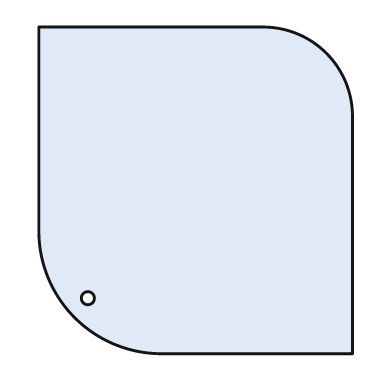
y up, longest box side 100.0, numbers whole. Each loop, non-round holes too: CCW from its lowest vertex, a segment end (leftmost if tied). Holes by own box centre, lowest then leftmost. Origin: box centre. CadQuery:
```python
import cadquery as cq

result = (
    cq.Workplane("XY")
    .moveTo(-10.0, -50.0)
    .lineTo(48.0, -50.0)
    .lineTo(48.0, 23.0)
    .threePointArc((40.0, 42.0), (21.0, 50.0))
    .lineTo(-48.0, 50.0)
    .lineTo(-48.0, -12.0)
    .threePointArc((-37.0, -39.0), (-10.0, -50.0))
    .close()
    .moveTo(-33.0, -33.0)
    .circle(2.0)
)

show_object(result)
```